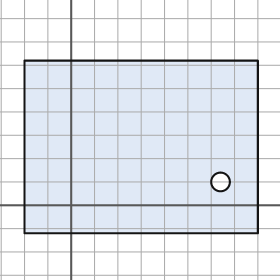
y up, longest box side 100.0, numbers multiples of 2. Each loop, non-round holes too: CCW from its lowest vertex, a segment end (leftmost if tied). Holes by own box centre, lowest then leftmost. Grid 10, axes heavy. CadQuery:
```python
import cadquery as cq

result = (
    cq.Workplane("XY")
    .moveTo(-20.0, -12.0)
    .lineTo(80.0, -12.0)
    .lineTo(80.0, 62.0)
    .lineTo(-20.0, 62.0)
    .close()
    .moveTo(64.0, 10.0)
    .circle(4.0)
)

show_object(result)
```